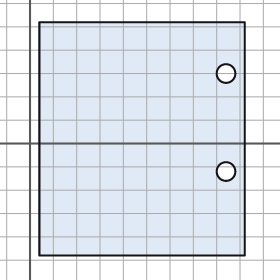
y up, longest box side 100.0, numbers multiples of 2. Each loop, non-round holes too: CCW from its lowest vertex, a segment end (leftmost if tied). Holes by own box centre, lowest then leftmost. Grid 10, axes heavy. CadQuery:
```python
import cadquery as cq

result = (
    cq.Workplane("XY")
    .moveTo(4.0, -48.0)
    .lineTo(92.0, -48.0)
    .lineTo(92.0, 52.0)
    .lineTo(4.0, 52.0)
    .close()
    .moveTo(84.0, -12.0)
    .circle(4.0)
    .moveTo(84.0, 30.0)
    .circle(4.0)
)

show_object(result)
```